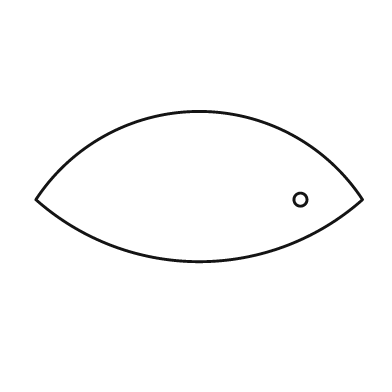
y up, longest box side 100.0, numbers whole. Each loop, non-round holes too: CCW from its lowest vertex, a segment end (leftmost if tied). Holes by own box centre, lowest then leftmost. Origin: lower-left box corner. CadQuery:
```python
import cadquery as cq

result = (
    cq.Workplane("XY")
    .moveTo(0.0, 19.0)
    .threePointArc((50.0, 0.0), (100.0, 19.0))
    .threePointArc((50.0, 46.0), (0.0, 19.0))
    .close()
    .moveTo(81.0, 19.0)
    .circle(2.0)
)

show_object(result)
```